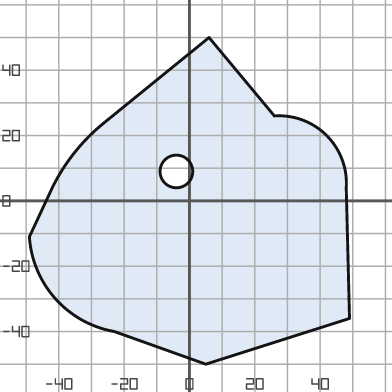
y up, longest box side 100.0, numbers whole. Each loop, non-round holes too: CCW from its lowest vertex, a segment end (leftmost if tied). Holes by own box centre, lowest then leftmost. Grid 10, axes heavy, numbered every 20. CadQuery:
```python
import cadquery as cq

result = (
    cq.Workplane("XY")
    .moveTo(5.0, -50.0)
    .lineTo(49.0, -36.0)
    .lineTo(48.0, 4.0)
    .threePointArc((42.0, 20.0), (26.0, 26.0))
    .lineTo(6.0, 50.0)
    .lineTo(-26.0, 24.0)
    .threePointArc((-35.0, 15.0), (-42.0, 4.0))
    .lineTo(-49.0, -11.0)
    .threePointArc((-41.0, -30.0), (-23.0, -40.0))
    .close()
    .moveTo(-4.0, 9.0)
    .circle(5.0)
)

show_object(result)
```